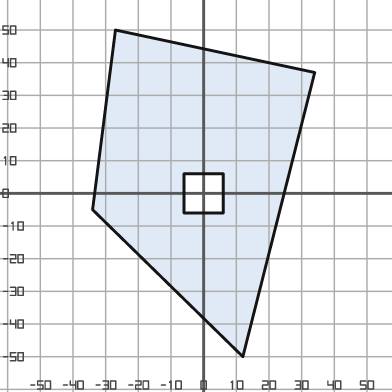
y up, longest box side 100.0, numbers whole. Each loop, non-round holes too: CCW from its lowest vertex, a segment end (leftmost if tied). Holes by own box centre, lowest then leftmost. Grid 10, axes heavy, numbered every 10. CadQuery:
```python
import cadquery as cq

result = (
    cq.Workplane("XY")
    .moveTo(12.0, -50.0)
    .lineTo(34.0, 37.0)
    .lineTo(-27.0, 50.0)
    .lineTo(-34.0, -5.0)
    .close()
    .moveTo(-6.0, -6.0)
    .lineTo(6.0, -6.0)
    .lineTo(6.0, 6.0)
    .lineTo(-6.0, 6.0)
    .close()
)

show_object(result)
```